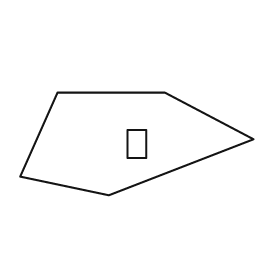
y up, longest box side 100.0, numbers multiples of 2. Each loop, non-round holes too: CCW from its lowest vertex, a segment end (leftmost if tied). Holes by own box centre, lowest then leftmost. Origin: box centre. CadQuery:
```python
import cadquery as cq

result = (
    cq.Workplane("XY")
    .moveTo(-12.0, -22.0)
    .lineTo(50.0, 2.0)
    .lineTo(12.0, 22.0)
    .lineTo(-34.0, 22.0)
    .lineTo(-50.0, -14.0)
    .close()
    .moveTo(-4.0, -6.0)
    .lineTo(4.0, -6.0)
    .lineTo(4.0, 6.0)
    .lineTo(-4.0, 6.0)
    .close()
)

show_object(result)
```